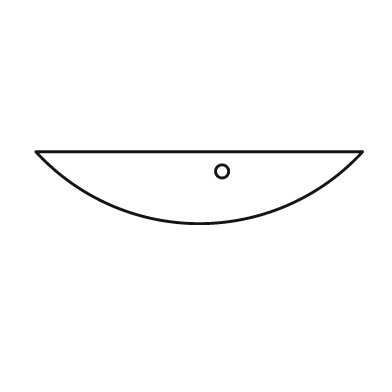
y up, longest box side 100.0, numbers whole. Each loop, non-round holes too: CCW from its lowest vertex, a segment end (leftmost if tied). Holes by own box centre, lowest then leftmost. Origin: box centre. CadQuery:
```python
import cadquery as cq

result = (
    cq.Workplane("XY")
    .moveTo(-50.0, 11.0)
    .threePointArc((0.0, -11.0), (50.0, 11.0))
    .close()
    .moveTo(7.0, 5.0)
    .circle(2.0)
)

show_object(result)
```